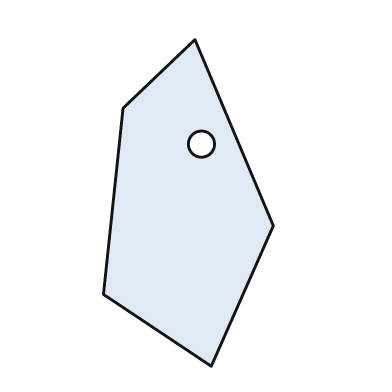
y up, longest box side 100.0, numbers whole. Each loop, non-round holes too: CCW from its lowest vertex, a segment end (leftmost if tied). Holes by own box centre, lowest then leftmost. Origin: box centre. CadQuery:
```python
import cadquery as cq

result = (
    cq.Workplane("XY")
    .moveTo(7.0, -50.0)
    .lineTo(26.0, -7.0)
    .lineTo(2.0, 50.0)
    .lineTo(-20.0, 29.0)
    .lineTo(-26.0, -28.0)
    .close()
    .moveTo(4.0, 18.0)
    .circle(4.0)
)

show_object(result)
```